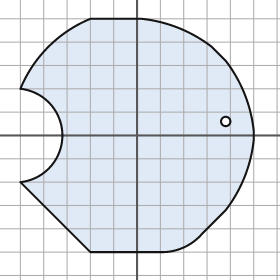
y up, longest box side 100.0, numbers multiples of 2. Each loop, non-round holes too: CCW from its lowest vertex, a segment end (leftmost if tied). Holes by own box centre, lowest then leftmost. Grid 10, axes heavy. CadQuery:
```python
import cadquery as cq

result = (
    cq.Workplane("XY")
    .moveTo(-20.0, -50.0)
    .lineTo(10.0, -50.0)
    .threePointArc((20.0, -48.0), (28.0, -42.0))
    .lineTo(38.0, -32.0)
    .threePointArc((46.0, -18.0), (50.0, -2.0))
    .lineTo(50.0, 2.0)
    .threePointArc((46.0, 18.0), (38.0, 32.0))
    .lineTo(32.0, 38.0)
    .threePointArc((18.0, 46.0), (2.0, 50.0))
    .lineTo(-20.0, 50.0)
    .threePointArc((-38.0, 38.0), (-50.0, 20.0))
    .threePointArc((-32.0, 0.0), (-50.0, -20.0))
    .close()
    .moveTo(38.0, 6.0)
    .circle(2.0)
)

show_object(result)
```